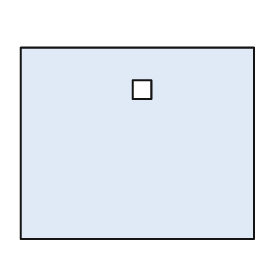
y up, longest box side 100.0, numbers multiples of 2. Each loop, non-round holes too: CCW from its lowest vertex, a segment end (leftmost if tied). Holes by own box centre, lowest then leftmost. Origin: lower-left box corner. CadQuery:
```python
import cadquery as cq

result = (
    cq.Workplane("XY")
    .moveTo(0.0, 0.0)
    .lineTo(100.0, 0.0)
    .lineTo(100.0, 82.0)
    .lineTo(0.0, 82.0)
    .close()
    .moveTo(48.0, 60.0)
    .lineTo(56.0, 60.0)
    .lineTo(56.0, 68.0)
    .lineTo(48.0, 68.0)
    .close()
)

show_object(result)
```